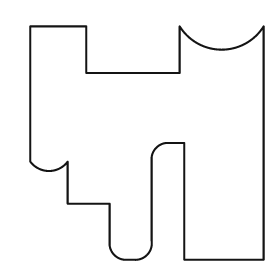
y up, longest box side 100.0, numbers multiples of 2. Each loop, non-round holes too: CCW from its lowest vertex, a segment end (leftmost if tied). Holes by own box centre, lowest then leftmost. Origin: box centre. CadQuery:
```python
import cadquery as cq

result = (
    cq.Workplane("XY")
    .moveTo(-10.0, -50.0)
    .lineTo(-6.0, -50.0)
    .threePointArc((0.0, -48.0), (2.0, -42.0))
    .lineTo(2.0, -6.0)
    .threePointArc((4.0, -2.0), (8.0, 0.0))
    .lineTo(16.0, 0.0)
    .lineTo(16.0, -50.0)
    .lineTo(50.0, -50.0)
    .lineTo(50.0, 50.0)
    .threePointArc((32.0, 40.0), (14.0, 50.0))
    .lineTo(14.0, 30.0)
    .lineTo(-26.0, 30.0)
    .lineTo(-26.0, 50.0)
    .lineTo(-50.0, 50.0)
    .lineTo(-50.0, -8.0)
    .threePointArc((-42.0, -12.0), (-34.0, -8.0))
    .lineTo(-34.0, -26.0)
    .lineTo(-16.0, -26.0)
    .lineTo(-16.0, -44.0)
    .threePointArc((-14.0, -48.0), (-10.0, -50.0))
    .close()
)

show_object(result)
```